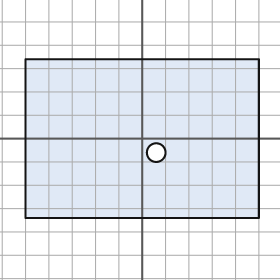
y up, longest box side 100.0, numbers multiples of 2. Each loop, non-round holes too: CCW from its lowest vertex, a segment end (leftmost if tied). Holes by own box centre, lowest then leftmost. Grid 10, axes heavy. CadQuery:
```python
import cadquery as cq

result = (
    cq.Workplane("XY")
    .moveTo(-50.0, -34.0)
    .lineTo(50.0, -34.0)
    .lineTo(50.0, 34.0)
    .lineTo(-50.0, 34.0)
    .close()
    .moveTo(6.0, -6.0)
    .circle(4.0)
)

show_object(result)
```